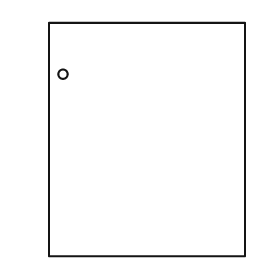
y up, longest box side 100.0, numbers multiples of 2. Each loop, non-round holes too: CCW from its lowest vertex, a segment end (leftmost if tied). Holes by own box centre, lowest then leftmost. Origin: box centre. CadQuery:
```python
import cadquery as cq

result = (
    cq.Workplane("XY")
    .moveTo(-42.0, -50.0)
    .lineTo(42.0, -50.0)
    .lineTo(42.0, 50.0)
    .lineTo(-42.0, 50.0)
    .close()
    .moveTo(-36.0, 28.0)
    .circle(2.0)
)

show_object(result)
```